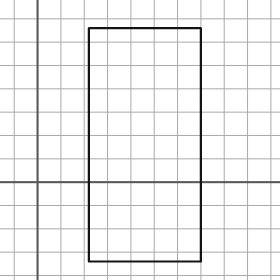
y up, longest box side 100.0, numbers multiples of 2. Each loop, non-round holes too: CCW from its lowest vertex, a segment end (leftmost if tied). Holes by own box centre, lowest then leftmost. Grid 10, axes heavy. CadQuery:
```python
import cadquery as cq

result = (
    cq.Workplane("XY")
    .moveTo(22.0, -34.0)
    .lineTo(70.0, -34.0)
    .lineTo(70.0, 66.0)
    .lineTo(22.0, 66.0)
    .close()
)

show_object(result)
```